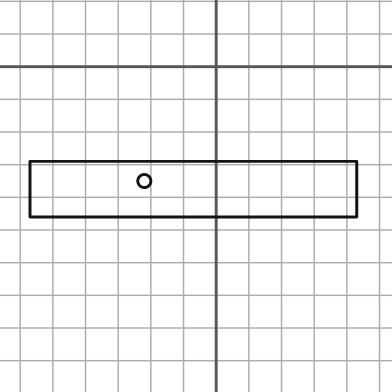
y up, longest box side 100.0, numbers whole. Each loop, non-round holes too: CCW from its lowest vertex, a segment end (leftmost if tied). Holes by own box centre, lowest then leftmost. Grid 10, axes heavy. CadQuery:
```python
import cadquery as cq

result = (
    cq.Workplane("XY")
    .moveTo(-57.0, -46.0)
    .lineTo(43.0, -46.0)
    .lineTo(43.0, -29.0)
    .lineTo(-57.0, -29.0)
    .close()
    .moveTo(-22.0, -35.0)
    .circle(2.0)
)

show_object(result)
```